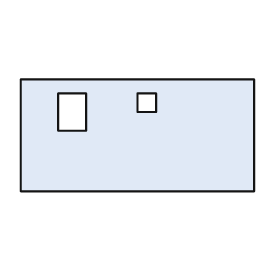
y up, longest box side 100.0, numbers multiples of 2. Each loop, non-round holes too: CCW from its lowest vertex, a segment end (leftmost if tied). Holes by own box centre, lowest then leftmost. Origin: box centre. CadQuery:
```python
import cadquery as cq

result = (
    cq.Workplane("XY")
    .moveTo(-50.0, -24.0)
    .lineTo(50.0, -24.0)
    .lineTo(50.0, 24.0)
    .lineTo(-50.0, 24.0)
    .close()
    .moveTo(-34.0, 2.0)
    .lineTo(-22.0, 2.0)
    .lineTo(-22.0, 18.0)
    .lineTo(-34.0, 18.0)
    .close()
    .moveTo(0.0, 10.0)
    .lineTo(8.0, 10.0)
    .lineTo(8.0, 18.0)
    .lineTo(0.0, 18.0)
    .close()
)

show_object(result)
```